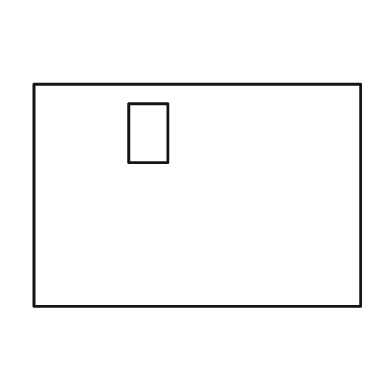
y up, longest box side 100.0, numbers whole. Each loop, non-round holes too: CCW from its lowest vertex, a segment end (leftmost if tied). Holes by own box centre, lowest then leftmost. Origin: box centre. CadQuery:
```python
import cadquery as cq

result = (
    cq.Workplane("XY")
    .moveTo(-50.0, -34.0)
    .lineTo(50.0, -34.0)
    .lineTo(50.0, 34.0)
    .lineTo(-50.0, 34.0)
    .close()
    .moveTo(-21.0, 10.0)
    .lineTo(-9.0, 10.0)
    .lineTo(-9.0, 28.0)
    .lineTo(-21.0, 28.0)
    .close()
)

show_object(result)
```